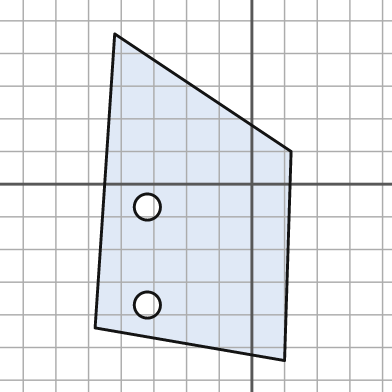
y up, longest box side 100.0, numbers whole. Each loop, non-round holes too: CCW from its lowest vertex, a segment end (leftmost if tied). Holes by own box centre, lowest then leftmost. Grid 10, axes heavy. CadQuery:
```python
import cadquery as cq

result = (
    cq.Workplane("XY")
    .moveTo(10.0, -54.0)
    .lineTo(12.0, 10.0)
    .lineTo(-42.0, 46.0)
    .lineTo(-48.0, -44.0)
    .close()
    .moveTo(-32.0, -37.0)
    .circle(4.0)
    .moveTo(-32.0, -7.0)
    .circle(4.0)
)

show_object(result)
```